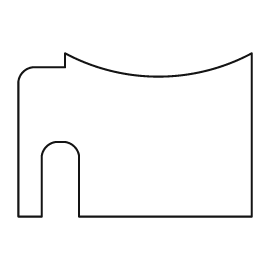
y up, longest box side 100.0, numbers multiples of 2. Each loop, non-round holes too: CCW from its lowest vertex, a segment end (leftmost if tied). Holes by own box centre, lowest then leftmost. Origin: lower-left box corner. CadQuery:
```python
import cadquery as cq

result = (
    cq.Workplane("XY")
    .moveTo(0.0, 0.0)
    .lineTo(10.0, 0.0)
    .lineTo(10.0, 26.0)
    .threePointArc((12.0, 30.0), (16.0, 32.0))
    .lineTo(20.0, 32.0)
    .threePointArc((24.0, 30.0), (26.0, 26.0))
    .lineTo(26.0, 0.0)
    .lineTo(100.0, 0.0)
    .lineTo(100.0, 70.0)
    .threePointArc((60.0, 60.0), (20.0, 70.0))
    .lineTo(20.0, 64.0)
    .lineTo(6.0, 64.0)
    .threePointArc((2.0, 62.0), (0.0, 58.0))
    .close()
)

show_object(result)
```